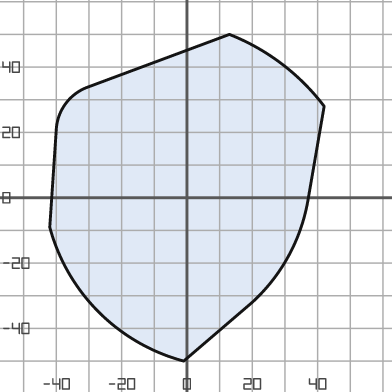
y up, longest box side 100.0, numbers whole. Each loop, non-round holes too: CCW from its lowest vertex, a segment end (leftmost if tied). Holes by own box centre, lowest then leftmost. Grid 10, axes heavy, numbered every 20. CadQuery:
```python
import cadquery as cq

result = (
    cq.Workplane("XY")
    .moveTo(-1.0, -50.0)
    .lineTo(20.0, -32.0)
    .threePointArc((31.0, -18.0), (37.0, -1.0))
    .lineTo(42.0, 28.0)
    .threePointArc((29.0, 41.0), (13.0, 50.0))
    .lineTo(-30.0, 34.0)
    .threePointArc((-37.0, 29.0), (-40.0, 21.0))
    .lineTo(-42.0, -9.0)
    .threePointArc((-27.0, -35.0), (-1.0, -50.0))
    .close()
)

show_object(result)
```